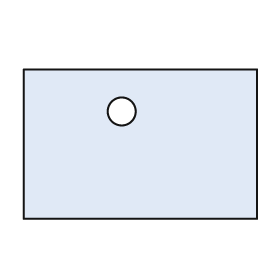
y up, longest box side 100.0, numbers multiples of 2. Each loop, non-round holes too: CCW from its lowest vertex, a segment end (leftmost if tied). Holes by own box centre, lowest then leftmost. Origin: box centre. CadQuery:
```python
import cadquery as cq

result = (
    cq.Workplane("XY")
    .moveTo(-50.0, -32.0)
    .lineTo(50.0, -32.0)
    .lineTo(50.0, 32.0)
    .lineTo(-50.0, 32.0)
    .close()
    .moveTo(-8.0, 14.0)
    .circle(6.0)
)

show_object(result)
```